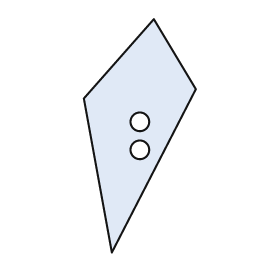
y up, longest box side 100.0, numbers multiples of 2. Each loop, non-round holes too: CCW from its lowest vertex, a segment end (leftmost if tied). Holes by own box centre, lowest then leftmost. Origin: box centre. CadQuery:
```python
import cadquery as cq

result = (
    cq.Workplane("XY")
    .moveTo(-12.0, -50.0)
    .lineTo(24.0, 20.0)
    .lineTo(6.0, 50.0)
    .lineTo(-24.0, 16.0)
    .close()
    .moveTo(0.0, -6.0)
    .circle(4.0)
    .moveTo(0.0, 6.0)
    .circle(4.0)
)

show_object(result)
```